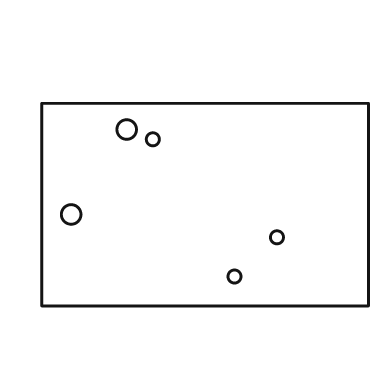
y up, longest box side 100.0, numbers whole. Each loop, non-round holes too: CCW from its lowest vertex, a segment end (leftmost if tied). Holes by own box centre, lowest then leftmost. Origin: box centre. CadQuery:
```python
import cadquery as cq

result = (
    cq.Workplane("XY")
    .moveTo(-50.0, -31.0)
    .lineTo(50.0, -31.0)
    .lineTo(50.0, 31.0)
    .lineTo(-50.0, 31.0)
    .close()
    .moveTo(9.0, -22.0)
    .circle(2.0)
    .moveTo(22.0, -10.0)
    .circle(2.0)
    .moveTo(-41.0, -3.0)
    .circle(3.0)
    .moveTo(-16.0, 20.0)
    .circle(2.0)
    .moveTo(-24.0, 23.0)
    .circle(3.0)
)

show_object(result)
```